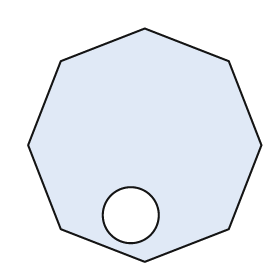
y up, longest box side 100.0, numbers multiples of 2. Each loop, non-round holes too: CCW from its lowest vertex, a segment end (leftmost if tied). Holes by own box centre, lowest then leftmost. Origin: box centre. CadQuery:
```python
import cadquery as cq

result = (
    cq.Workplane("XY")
    .moveTo(0.0, -50.0)
    .lineTo(36.0, -36.0)
    .lineTo(50.0, 0.0)
    .lineTo(36.0, 36.0)
    .lineTo(0.0, 50.0)
    .lineTo(-36.0, 36.0)
    .lineTo(-50.0, 0.0)
    .lineTo(-36.0, -36.0)
    .close()
    .moveTo(-6.0, -30.0)
    .circle(12.0)
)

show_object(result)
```